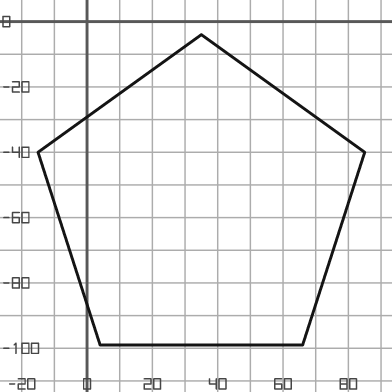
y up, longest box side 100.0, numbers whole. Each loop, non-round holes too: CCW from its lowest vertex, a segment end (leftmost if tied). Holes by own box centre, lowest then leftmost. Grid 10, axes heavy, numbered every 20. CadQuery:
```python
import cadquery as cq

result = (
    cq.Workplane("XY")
    .moveTo(4.0, -99.0)
    .lineTo(66.0, -99.0)
    .lineTo(85.0, -40.0)
    .lineTo(35.0, -4.0)
    .lineTo(-15.0, -40.0)
    .close()
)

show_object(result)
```